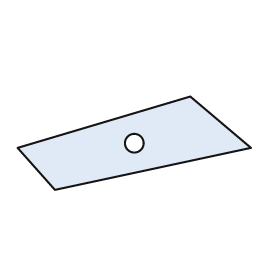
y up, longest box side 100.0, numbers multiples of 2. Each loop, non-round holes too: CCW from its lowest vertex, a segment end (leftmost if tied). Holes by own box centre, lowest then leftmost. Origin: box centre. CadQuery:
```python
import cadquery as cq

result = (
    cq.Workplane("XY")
    .moveTo(-34.0, -20.0)
    .lineTo(50.0, -2.0)
    .lineTo(24.0, 20.0)
    .lineTo(-50.0, -2.0)
    .close()
    .moveTo(0.0, 0.0)
    .circle(4.0)
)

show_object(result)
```